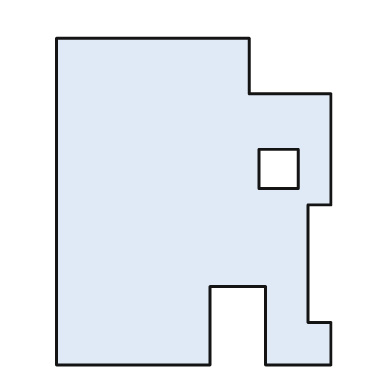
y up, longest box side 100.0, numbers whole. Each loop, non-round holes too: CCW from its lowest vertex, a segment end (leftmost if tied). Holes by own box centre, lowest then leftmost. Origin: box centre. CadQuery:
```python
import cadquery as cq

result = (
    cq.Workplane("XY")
    .moveTo(-42.0, -50.0)
    .lineTo(5.0, -50.0)
    .lineTo(5.0, -26.0)
    .lineTo(22.0, -26.0)
    .lineTo(22.0, -50.0)
    .lineTo(42.0, -50.0)
    .lineTo(42.0, -37.0)
    .lineTo(35.0, -37.0)
    .lineTo(35.0, -1.0)
    .lineTo(42.0, -1.0)
    .lineTo(42.0, 33.0)
    .lineTo(17.0, 33.0)
    .lineTo(17.0, 50.0)
    .lineTo(-42.0, 50.0)
    .close()
    .moveTo(20.0, 4.0)
    .lineTo(32.0, 4.0)
    .lineTo(32.0, 16.0)
    .lineTo(20.0, 16.0)
    .close()
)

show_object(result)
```